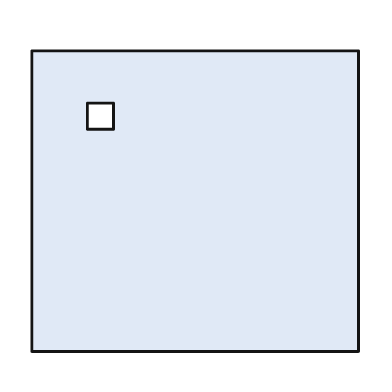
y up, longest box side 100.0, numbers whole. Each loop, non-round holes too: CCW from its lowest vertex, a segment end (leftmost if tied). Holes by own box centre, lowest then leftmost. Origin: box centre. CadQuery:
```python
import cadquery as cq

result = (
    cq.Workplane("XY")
    .moveTo(-50.0, -46.0)
    .lineTo(50.0, -46.0)
    .lineTo(50.0, 46.0)
    .lineTo(-50.0, 46.0)
    .close()
    .moveTo(-33.0, 22.0)
    .lineTo(-25.0, 22.0)
    .lineTo(-25.0, 30.0)
    .lineTo(-33.0, 30.0)
    .close()
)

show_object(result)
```